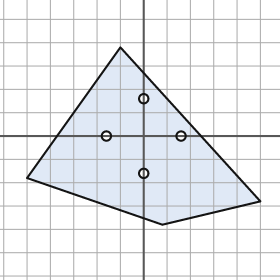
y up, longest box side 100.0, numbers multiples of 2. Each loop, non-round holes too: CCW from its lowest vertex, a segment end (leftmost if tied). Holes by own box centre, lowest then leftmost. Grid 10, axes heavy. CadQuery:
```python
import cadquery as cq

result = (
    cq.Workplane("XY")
    .moveTo(8.0, -38.0)
    .lineTo(50.0, -28.0)
    .lineTo(-10.0, 38.0)
    .lineTo(-50.0, -18.0)
    .close()
    .moveTo(0.0, -16.0)
    .circle(2.0)
    .moveTo(-16.0, 0.0)
    .circle(2.0)
    .moveTo(16.0, 0.0)
    .circle(2.0)
    .moveTo(0.0, 16.0)
    .circle(2.0)
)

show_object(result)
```